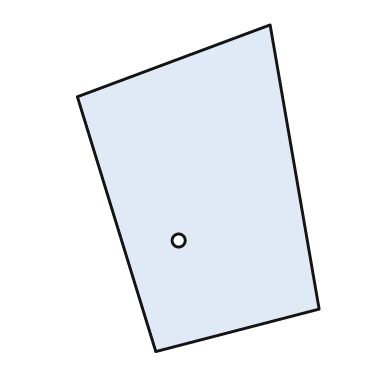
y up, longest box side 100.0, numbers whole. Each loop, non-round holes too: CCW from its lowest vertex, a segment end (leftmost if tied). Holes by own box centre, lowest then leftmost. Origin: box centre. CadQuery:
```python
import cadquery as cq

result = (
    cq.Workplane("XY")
    .moveTo(-13.0, -50.0)
    .lineTo(37.0, -37.0)
    .lineTo(22.0, 50.0)
    .lineTo(-37.0, 28.0)
    .close()
    .moveTo(-6.0, -16.0)
    .circle(2.0)
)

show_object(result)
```